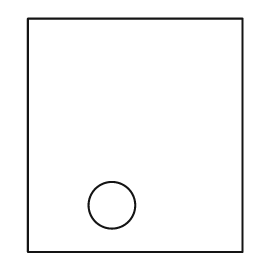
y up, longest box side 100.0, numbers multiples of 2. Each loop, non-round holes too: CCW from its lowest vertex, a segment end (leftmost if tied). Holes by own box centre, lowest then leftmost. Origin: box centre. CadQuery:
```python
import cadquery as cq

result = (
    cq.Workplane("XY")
    .moveTo(-46.0, -50.0)
    .lineTo(46.0, -50.0)
    .lineTo(46.0, 50.0)
    .lineTo(-46.0, 50.0)
    .close()
    .moveTo(-10.0, -30.0)
    .circle(10.0)
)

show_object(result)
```